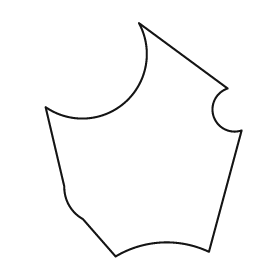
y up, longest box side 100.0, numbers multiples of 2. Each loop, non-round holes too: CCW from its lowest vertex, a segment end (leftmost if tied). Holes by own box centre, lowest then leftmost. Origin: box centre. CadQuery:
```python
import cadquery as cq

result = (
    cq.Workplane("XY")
    .moveTo(-12.0, -50.0)
    .threePointArc((8.0, -44.0), (28.0, -48.0))
    .lineTo(42.0, 4.0)
    .threePointArc((30.0, 10.0), (36.0, 22.0))
    .lineTo(-2.0, 50.0)
    .threePointArc((-8.0, 16.0), (-42.0, 14.0))
    .lineTo(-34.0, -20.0)
    .threePointArc((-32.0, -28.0), (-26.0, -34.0))
    .close()
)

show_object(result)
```